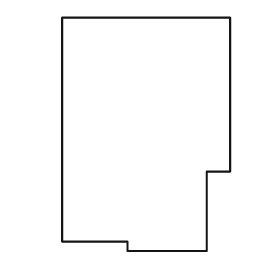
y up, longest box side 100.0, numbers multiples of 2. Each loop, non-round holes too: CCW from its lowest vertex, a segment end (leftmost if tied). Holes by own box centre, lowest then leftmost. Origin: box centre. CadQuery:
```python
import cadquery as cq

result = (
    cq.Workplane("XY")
    .moveTo(-8.0, -50.0)
    .lineTo(26.0, -50.0)
    .lineTo(26.0, -16.0)
    .lineTo(36.0, -16.0)
    .lineTo(36.0, 50.0)
    .lineTo(-36.0, 50.0)
    .lineTo(-36.0, -46.0)
    .lineTo(-8.0, -46.0)
    .close()
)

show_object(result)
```